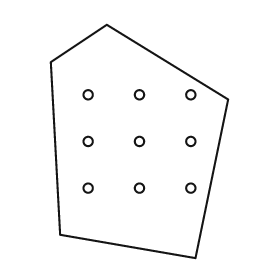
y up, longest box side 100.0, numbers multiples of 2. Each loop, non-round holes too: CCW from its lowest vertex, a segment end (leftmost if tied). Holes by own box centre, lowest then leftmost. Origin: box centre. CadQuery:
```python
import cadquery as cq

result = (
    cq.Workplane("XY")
    .moveTo(24.0, -50.0)
    .lineTo(38.0, 18.0)
    .lineTo(-14.0, 50.0)
    .lineTo(-38.0, 34.0)
    .lineTo(-34.0, -40.0)
    .close()
    .moveTo(-22.0, -20.0)
    .circle(2.0)
    .moveTo(0.0, -20.0)
    .circle(2.0)
    .moveTo(22.0, -20.0)
    .circle(2.0)
    .moveTo(-22.0, 0.0)
    .circle(2.0)
    .moveTo(0.0, 0.0)
    .circle(2.0)
    .moveTo(22.0, 0.0)
    .circle(2.0)
    .moveTo(-22.0, 20.0)
    .circle(2.0)
    .moveTo(0.0, 20.0)
    .circle(2.0)
    .moveTo(22.0, 20.0)
    .circle(2.0)
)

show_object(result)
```